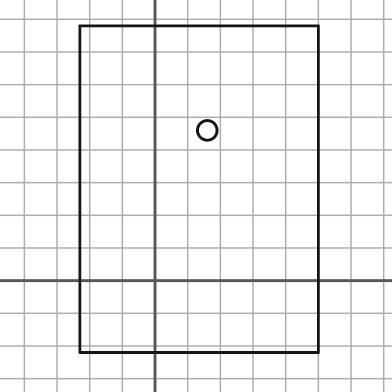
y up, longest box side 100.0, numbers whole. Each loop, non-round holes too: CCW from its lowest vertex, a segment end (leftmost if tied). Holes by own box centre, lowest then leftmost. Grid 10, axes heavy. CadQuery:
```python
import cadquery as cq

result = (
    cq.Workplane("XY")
    .moveTo(-23.0, -22.0)
    .lineTo(50.0, -22.0)
    .lineTo(50.0, 78.0)
    .lineTo(-23.0, 78.0)
    .close()
    .moveTo(16.0, 46.0)
    .circle(3.0)
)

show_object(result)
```